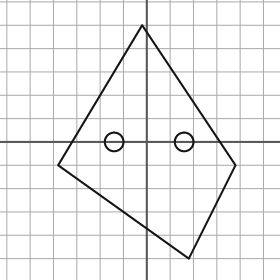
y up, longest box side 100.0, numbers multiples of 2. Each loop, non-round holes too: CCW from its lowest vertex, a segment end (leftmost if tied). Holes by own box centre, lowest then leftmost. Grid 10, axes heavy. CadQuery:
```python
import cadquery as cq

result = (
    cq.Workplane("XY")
    .moveTo(18.0, -50.0)
    .lineTo(38.0, -10.0)
    .lineTo(-2.0, 50.0)
    .lineTo(-38.0, -10.0)
    .close()
    .moveTo(-14.0, 0.0)
    .circle(4.0)
    .moveTo(16.0, 0.0)
    .circle(4.0)
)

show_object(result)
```